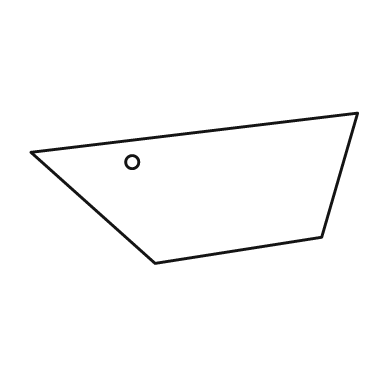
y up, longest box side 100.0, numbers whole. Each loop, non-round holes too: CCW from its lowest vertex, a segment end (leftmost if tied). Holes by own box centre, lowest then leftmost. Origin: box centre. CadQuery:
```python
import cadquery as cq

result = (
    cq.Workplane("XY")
    .moveTo(-12.0, -23.0)
    .lineTo(39.0, -15.0)
    .lineTo(50.0, 23.0)
    .lineTo(-50.0, 11.0)
    .close()
    .moveTo(-19.0, 8.0)
    .circle(2.0)
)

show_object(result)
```